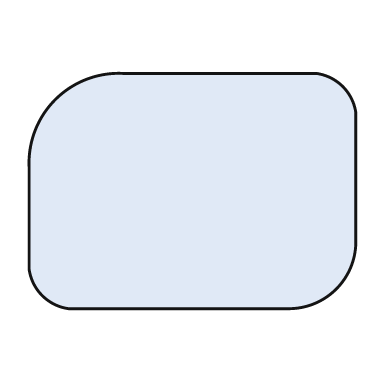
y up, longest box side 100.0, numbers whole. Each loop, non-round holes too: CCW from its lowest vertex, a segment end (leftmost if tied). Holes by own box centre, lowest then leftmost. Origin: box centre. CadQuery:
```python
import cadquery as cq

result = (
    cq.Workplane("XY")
    .moveTo(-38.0, -36.0)
    .lineTo(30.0, -36.0)
    .threePointArc((44.0, -30.0), (50.0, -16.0))
    .lineTo(50.0, 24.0)
    .threePointArc((46.0, 32.0), (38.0, 36.0))
    .lineTo(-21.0, 36.0)
    .threePointArc((-42.0, 28.0), (-50.0, 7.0))
    .lineTo(-50.0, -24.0)
    .threePointArc((-46.0, -32.0), (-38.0, -36.0))
    .close()
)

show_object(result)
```